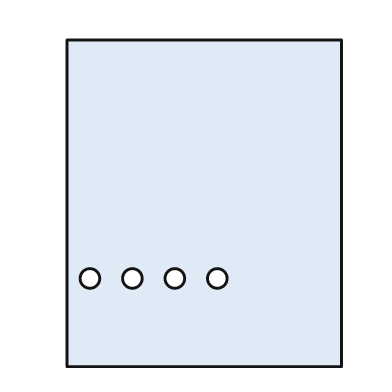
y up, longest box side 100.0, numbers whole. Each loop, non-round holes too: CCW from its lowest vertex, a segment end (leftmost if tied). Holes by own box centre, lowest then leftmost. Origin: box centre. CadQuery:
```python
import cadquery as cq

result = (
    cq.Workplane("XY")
    .moveTo(-42.0, -50.0)
    .lineTo(42.0, -50.0)
    .lineTo(42.0, 50.0)
    .lineTo(-42.0, 50.0)
    .close()
    .moveTo(-35.0, -23.0)
    .circle(3.0)
    .moveTo(-22.0, -23.0)
    .circle(3.0)
    .moveTo(-9.0, -23.0)
    .circle(3.0)
    .moveTo(4.0, -23.0)
    .circle(3.0)
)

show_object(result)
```